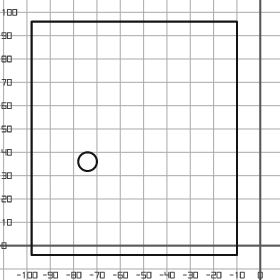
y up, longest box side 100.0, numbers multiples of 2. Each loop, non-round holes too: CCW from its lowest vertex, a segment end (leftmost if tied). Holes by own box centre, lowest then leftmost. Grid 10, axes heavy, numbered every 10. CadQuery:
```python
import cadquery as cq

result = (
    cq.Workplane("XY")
    .moveTo(-98.0, -4.0)
    .lineTo(-10.0, -4.0)
    .lineTo(-10.0, 96.0)
    .lineTo(-98.0, 96.0)
    .close()
    .moveTo(-74.0, 36.0)
    .circle(4.0)
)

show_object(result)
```